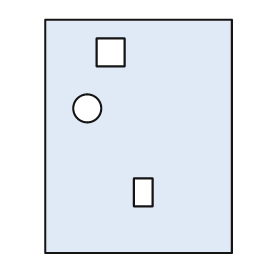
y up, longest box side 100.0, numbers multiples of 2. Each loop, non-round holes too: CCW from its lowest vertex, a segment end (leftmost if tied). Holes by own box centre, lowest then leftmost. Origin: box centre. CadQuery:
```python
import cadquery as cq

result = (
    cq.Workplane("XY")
    .moveTo(-40.0, -50.0)
    .lineTo(40.0, -50.0)
    .lineTo(40.0, 50.0)
    .lineTo(-40.0, 50.0)
    .close()
    .moveTo(-2.0, -30.0)
    .lineTo(6.0, -30.0)
    .lineTo(6.0, -18.0)
    .lineTo(-2.0, -18.0)
    .close()
    .moveTo(-22.0, 12.0)
    .circle(6.0)
    .moveTo(-18.0, 30.0)
    .lineTo(-6.0, 30.0)
    .lineTo(-6.0, 42.0)
    .lineTo(-18.0, 42.0)
    .close()
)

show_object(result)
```